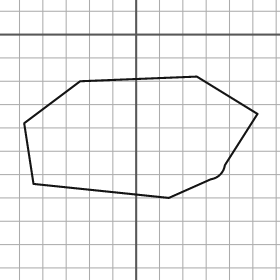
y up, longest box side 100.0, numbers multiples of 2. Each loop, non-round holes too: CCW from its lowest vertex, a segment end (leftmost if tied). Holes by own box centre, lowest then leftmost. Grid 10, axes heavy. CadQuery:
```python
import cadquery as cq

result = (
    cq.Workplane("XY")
    .moveTo(14.0, -70.0)
    .lineTo(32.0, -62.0)
    .threePointArc((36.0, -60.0), (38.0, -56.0))
    .lineTo(52.0, -34.0)
    .lineTo(26.0, -18.0)
    .lineTo(-24.0, -20.0)
    .lineTo(-48.0, -38.0)
    .lineTo(-44.0, -64.0)
    .close()
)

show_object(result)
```